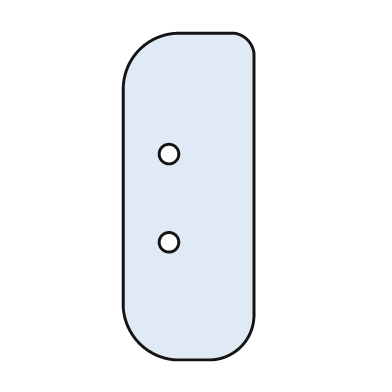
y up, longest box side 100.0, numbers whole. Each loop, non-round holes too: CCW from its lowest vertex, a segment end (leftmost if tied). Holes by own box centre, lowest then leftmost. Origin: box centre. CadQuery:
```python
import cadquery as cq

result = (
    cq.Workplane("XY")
    .moveTo(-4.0, -50.0)
    .lineTo(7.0, -50.0)
    .threePointArc((16.0, -46.0), (20.0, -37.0))
    .lineTo(20.0, 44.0)
    .threePointArc((18.0, 48.0), (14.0, 50.0))
    .lineTo(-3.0, 50.0)
    .threePointArc((-15.0, 45.0), (-20.0, 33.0))
    .lineTo(-20.0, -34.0)
    .threePointArc((-15.0, -45.0), (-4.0, -50.0))
    .close()
    .moveTo(-6.0, -14.0)
    .circle(3.0)
    .moveTo(-6.0, 13.0)
    .circle(3.0)
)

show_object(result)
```